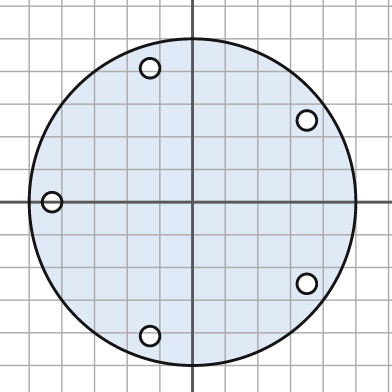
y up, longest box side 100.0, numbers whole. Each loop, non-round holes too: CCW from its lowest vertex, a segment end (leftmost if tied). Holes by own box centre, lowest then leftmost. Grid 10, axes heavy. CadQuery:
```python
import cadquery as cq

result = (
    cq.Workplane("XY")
    .moveTo(0.0, 0.0)
    .circle(50.0)
    .moveTo(-13.0, -41.0)
    .circle(3.0)
    .moveTo(35.0, -25.0)
    .circle(3.0)
    .moveTo(-43.0, 0.0)
    .circle(3.0)
    .moveTo(35.0, 25.0)
    .circle(3.0)
    .moveTo(-13.0, 41.0)
    .circle(3.0)
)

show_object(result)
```